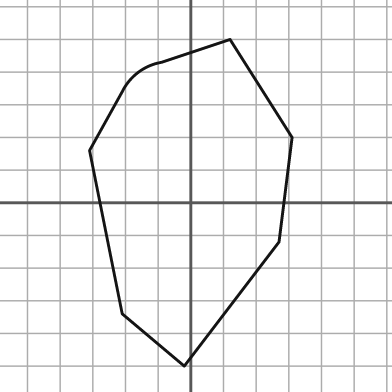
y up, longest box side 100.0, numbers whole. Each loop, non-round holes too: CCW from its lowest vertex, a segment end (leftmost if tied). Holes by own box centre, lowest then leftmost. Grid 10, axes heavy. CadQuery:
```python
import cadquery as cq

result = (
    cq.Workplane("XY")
    .moveTo(-2.0, -50.0)
    .lineTo(27.0, -12.0)
    .lineTo(31.0, 20.0)
    .lineTo(12.0, 50.0)
    .lineTo(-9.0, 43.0)
    .threePointArc((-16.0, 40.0), (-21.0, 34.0))
    .lineTo(-31.0, 16.0)
    .lineTo(-21.0, -34.0)
    .close()
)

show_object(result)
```